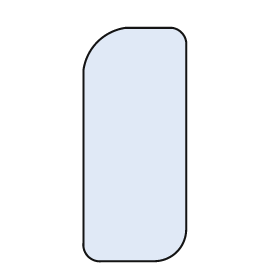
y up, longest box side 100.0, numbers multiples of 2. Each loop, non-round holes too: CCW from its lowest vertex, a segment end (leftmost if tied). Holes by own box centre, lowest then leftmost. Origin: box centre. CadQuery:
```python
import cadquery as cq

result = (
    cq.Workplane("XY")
    .moveTo(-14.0, -50.0)
    .lineTo(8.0, -50.0)
    .threePointArc((18.0, -46.0), (22.0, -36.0))
    .lineTo(22.0, 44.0)
    .threePointArc((20.0, 48.0), (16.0, 50.0))
    .lineTo(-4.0, 50.0)
    .threePointArc((-16.0, 44.0), (-22.0, 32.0))
    .lineTo(-22.0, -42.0)
    .threePointArc((-20.0, -48.0), (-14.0, -50.0))
    .close()
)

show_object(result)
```